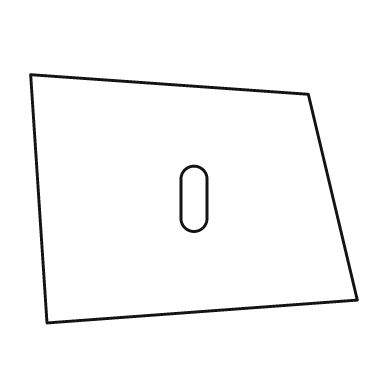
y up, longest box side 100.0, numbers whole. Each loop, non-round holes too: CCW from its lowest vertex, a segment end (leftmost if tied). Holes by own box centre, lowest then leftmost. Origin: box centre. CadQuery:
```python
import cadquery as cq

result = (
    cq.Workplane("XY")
    .moveTo(-45.0, -38.0)
    .lineTo(50.0, -31.0)
    .lineTo(35.0, 32.0)
    .lineTo(-50.0, 38.0)
    .close()
    .moveTo(-4.0, -6.0)
    .threePointArc((0.0, -10.0), (4.0, -6.0))
    .lineTo(4.0, 6.0)
    .threePointArc((0.0, 10.0), (-4.0, 6.0))
    .close()
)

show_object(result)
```